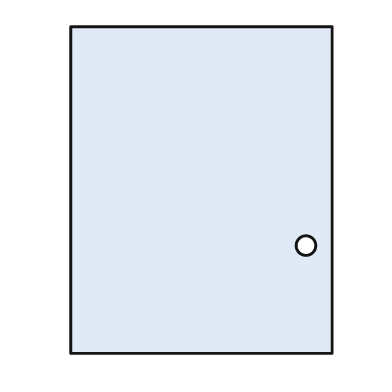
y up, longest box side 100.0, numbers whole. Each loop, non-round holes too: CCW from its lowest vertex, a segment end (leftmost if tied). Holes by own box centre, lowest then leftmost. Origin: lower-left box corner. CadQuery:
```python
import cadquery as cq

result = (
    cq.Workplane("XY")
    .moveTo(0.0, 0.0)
    .lineTo(80.0, 0.0)
    .lineTo(80.0, 100.0)
    .lineTo(0.0, 100.0)
    .close()
    .moveTo(72.0, 33.0)
    .circle(3.0)
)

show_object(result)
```